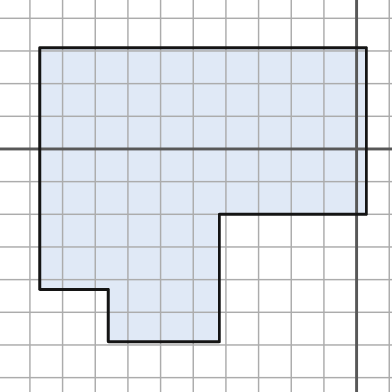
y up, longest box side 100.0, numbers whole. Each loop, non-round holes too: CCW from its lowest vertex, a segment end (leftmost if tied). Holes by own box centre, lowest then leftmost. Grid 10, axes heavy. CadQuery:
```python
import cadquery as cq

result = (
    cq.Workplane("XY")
    .moveTo(-76.0, -59.0)
    .lineTo(-42.0, -59.0)
    .lineTo(-42.0, -20.0)
    .lineTo(3.0, -20.0)
    .lineTo(3.0, 31.0)
    .lineTo(-97.0, 31.0)
    .lineTo(-97.0, -43.0)
    .lineTo(-76.0, -43.0)
    .close()
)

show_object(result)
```